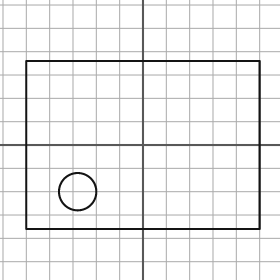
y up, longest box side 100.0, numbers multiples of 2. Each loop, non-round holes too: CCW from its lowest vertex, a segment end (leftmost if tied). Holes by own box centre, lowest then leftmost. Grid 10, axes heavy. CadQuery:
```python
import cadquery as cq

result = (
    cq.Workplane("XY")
    .moveTo(-50.0, -36.0)
    .lineTo(50.0, -36.0)
    .lineTo(50.0, 36.0)
    .lineTo(-50.0, 36.0)
    .close()
    .moveTo(-28.0, -20.0)
    .circle(8.0)
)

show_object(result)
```